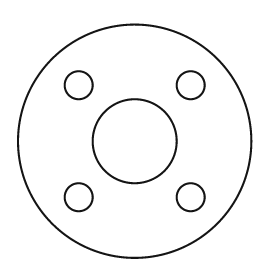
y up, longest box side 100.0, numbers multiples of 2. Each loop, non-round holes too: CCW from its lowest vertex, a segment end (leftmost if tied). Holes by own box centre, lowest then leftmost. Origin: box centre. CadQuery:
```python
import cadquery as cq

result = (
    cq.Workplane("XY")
    .moveTo(0.0, 0.0)
    .circle(50.0)
    .moveTo(-24.0, -24.0)
    .circle(6.0)
    .moveTo(24.0, -24.0)
    .circle(6.0)
    .moveTo(0.0, 0.0)
    .circle(18.0)
    .moveTo(-24.0, 24.0)
    .circle(6.0)
    .moveTo(24.0, 24.0)
    .circle(6.0)
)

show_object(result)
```